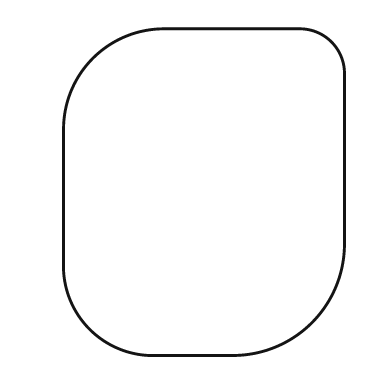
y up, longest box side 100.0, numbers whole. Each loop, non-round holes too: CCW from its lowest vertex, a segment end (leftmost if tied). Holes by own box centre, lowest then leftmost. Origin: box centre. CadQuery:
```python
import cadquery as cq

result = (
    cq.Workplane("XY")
    .moveTo(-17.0, -50.0)
    .lineTo(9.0, -50.0)
    .threePointArc((33.0, -40.0), (43.0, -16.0))
    .lineTo(43.0, 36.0)
    .threePointArc((39.0, 46.0), (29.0, 50.0))
    .lineTo(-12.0, 50.0)
    .threePointArc((-34.0, 41.0), (-43.0, 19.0))
    .lineTo(-43.0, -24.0)
    .threePointArc((-35.0, -42.0), (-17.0, -50.0))
    .close()
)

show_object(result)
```